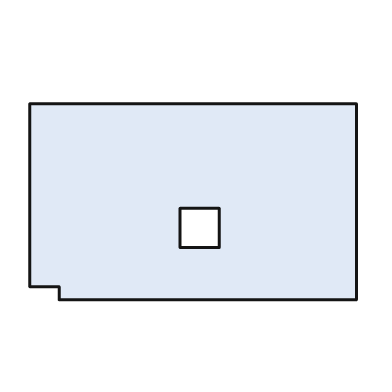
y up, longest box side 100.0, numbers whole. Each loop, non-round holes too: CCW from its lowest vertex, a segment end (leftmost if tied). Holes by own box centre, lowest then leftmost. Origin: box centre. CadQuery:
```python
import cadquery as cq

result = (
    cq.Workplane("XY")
    .moveTo(-41.0, -30.0)
    .lineTo(50.0, -30.0)
    .lineTo(50.0, 30.0)
    .lineTo(-50.0, 30.0)
    .lineTo(-50.0, -26.0)
    .lineTo(-41.0, -26.0)
    .close()
    .moveTo(-4.0, -14.0)
    .lineTo(8.0, -14.0)
    .lineTo(8.0, -2.0)
    .lineTo(-4.0, -2.0)
    .close()
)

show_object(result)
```